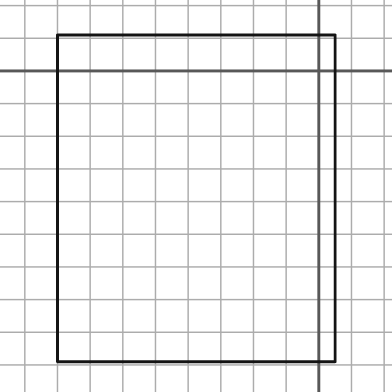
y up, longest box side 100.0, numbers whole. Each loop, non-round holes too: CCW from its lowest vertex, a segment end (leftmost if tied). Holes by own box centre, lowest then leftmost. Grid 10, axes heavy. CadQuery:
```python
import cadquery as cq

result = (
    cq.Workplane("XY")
    .moveTo(-80.0, -89.0)
    .lineTo(5.0, -89.0)
    .lineTo(5.0, 11.0)
    .lineTo(-80.0, 11.0)
    .close()
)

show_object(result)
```